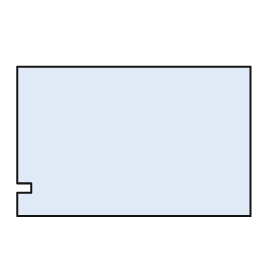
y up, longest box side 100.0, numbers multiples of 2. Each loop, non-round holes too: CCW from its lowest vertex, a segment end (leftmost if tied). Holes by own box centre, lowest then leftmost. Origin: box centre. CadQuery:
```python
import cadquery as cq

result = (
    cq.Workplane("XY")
    .moveTo(-50.0, -32.0)
    .lineTo(50.0, -32.0)
    .lineTo(50.0, 32.0)
    .lineTo(-50.0, 32.0)
    .lineTo(-50.0, -18.0)
    .lineTo(-44.0, -18.0)
    .lineTo(-44.0, -22.0)
    .lineTo(-50.0, -22.0)
    .close()
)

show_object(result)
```